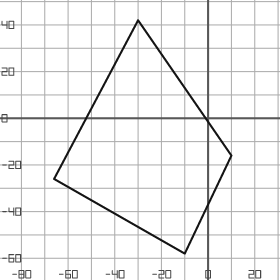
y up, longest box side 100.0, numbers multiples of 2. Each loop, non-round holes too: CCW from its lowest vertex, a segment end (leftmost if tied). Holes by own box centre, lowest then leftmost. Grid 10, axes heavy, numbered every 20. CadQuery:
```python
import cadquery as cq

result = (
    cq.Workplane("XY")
    .moveTo(-10.0, -58.0)
    .lineTo(10.0, -16.0)
    .lineTo(-30.0, 42.0)
    .lineTo(-66.0, -26.0)
    .close()
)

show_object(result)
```